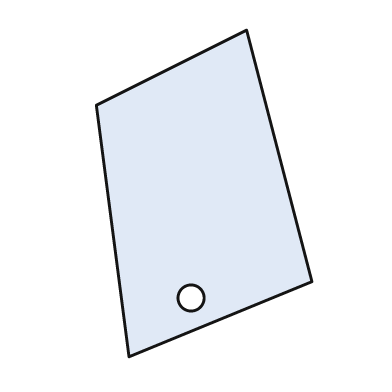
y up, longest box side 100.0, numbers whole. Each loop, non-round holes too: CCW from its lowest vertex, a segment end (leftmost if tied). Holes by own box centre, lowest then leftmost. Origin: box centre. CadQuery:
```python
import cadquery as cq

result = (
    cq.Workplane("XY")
    .moveTo(-23.0, -50.0)
    .lineTo(33.0, -27.0)
    .lineTo(13.0, 50.0)
    .lineTo(-33.0, 27.0)
    .close()
    .moveTo(-4.0, -32.0)
    .circle(4.0)
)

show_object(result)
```